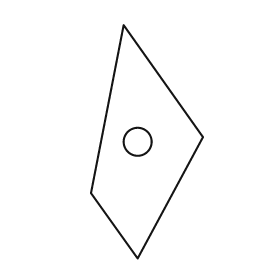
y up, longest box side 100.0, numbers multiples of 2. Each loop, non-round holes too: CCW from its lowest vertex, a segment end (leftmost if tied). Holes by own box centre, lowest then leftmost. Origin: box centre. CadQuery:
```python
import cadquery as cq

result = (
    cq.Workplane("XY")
    .moveTo(-4.0, -50.0)
    .lineTo(24.0, 2.0)
    .lineTo(-10.0, 50.0)
    .lineTo(-24.0, -22.0)
    .close()
    .moveTo(-4.0, 0.0)
    .circle(6.0)
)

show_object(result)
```